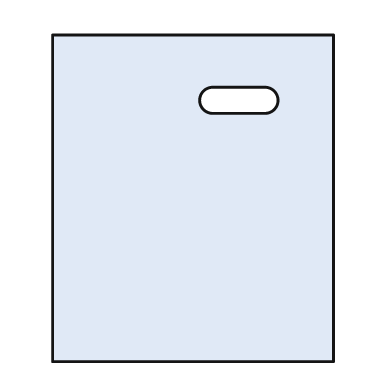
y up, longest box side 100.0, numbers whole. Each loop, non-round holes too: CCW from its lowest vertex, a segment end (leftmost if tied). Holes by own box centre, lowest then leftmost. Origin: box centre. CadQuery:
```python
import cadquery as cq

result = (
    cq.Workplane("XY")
    .moveTo(-43.0, -50.0)
    .lineTo(43.0, -50.0)
    .lineTo(43.0, 50.0)
    .lineTo(-43.0, 50.0)
    .close()
    .moveTo(6.0, 26.0)
    .lineTo(22.0, 26.0)
    .threePointArc((26.0, 30.0), (22.0, 34.0))
    .lineTo(6.0, 34.0)
    .threePointArc((2.0, 30.0), (6.0, 26.0))
    .close()
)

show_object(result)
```